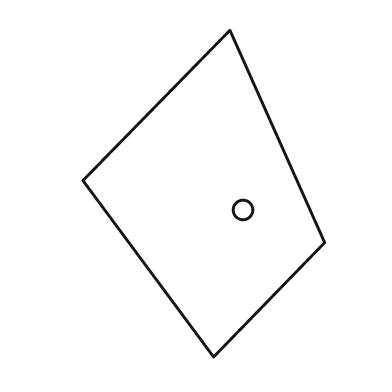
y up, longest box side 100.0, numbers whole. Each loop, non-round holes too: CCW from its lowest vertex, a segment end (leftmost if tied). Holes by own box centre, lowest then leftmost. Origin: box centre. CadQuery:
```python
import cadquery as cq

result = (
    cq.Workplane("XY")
    .moveTo(3.0, -50.0)
    .lineTo(37.0, -15.0)
    .lineTo(8.0, 50.0)
    .lineTo(-37.0, 4.0)
    .close()
    .moveTo(12.0, -5.0)
    .circle(3.0)
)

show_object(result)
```